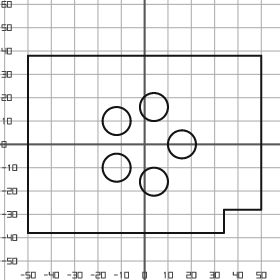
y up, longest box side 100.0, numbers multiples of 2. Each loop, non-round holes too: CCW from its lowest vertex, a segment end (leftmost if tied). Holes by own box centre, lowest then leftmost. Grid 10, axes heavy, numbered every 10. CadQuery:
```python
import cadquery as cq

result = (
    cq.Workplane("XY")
    .moveTo(-50.0, -38.0)
    .lineTo(34.0, -38.0)
    .lineTo(34.0, -28.0)
    .lineTo(50.0, -28.0)
    .lineTo(50.0, 38.0)
    .lineTo(-50.0, 38.0)
    .close()
    .moveTo(4.0, -16.0)
    .circle(6.0)
    .moveTo(-12.0, -10.0)
    .circle(6.0)
    .moveTo(16.0, 0.0)
    .circle(6.0)
    .moveTo(-12.0, 10.0)
    .circle(6.0)
    .moveTo(4.0, 16.0)
    .circle(6.0)
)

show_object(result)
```